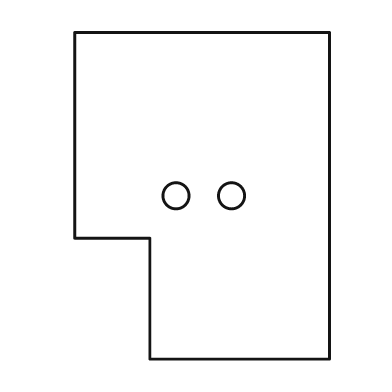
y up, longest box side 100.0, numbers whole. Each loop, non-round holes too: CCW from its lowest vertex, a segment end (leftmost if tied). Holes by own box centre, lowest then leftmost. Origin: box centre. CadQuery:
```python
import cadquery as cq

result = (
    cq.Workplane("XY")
    .moveTo(-16.0, -50.0)
    .lineTo(39.0, -50.0)
    .lineTo(39.0, 50.0)
    .lineTo(-39.0, 50.0)
    .lineTo(-39.0, -13.0)
    .lineTo(-16.0, -13.0)
    .close()
    .moveTo(-8.0, 0.0)
    .circle(4.0)
    .moveTo(9.0, 0.0)
    .circle(4.0)
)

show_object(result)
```